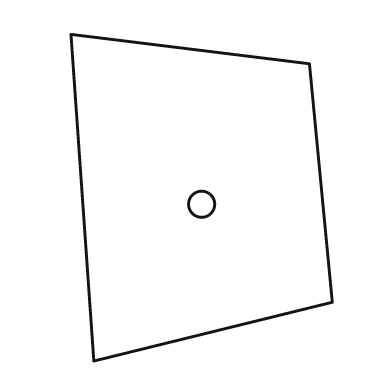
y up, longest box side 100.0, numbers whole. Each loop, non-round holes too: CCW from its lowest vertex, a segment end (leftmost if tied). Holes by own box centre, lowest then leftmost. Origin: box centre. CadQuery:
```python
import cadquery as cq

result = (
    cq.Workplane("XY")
    .moveTo(-33.0, -50.0)
    .lineTo(40.0, -32.0)
    .lineTo(33.0, 41.0)
    .lineTo(-40.0, 50.0)
    .close()
    .moveTo(0.0, -2.0)
    .circle(4.0)
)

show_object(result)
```